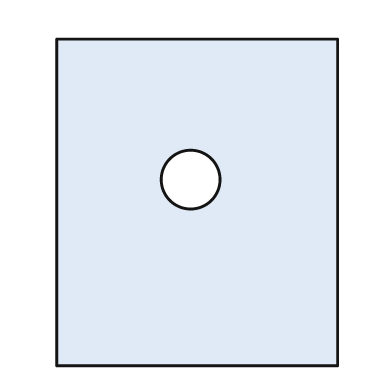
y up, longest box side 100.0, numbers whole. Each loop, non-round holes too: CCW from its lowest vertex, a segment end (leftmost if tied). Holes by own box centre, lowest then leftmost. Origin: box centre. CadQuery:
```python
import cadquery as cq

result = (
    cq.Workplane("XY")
    .moveTo(-43.0, -50.0)
    .lineTo(43.0, -50.0)
    .lineTo(43.0, 50.0)
    .lineTo(-43.0, 50.0)
    .close()
    .moveTo(-2.0, 7.0)
    .circle(9.0)
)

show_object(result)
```